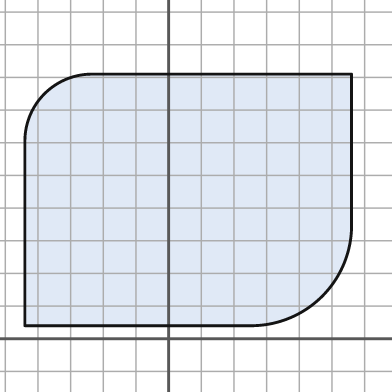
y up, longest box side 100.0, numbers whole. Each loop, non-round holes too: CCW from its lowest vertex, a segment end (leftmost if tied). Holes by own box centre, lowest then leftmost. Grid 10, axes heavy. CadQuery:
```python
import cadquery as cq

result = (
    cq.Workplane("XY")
    .moveTo(-44.0, 4.0)
    .lineTo(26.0, 4.0)
    .threePointArc((47.0, 13.0), (56.0, 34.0))
    .lineTo(56.0, 81.0)
    .lineTo(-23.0, 81.0)
    .threePointArc((-38.0, 75.0), (-44.0, 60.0))
    .close()
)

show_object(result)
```